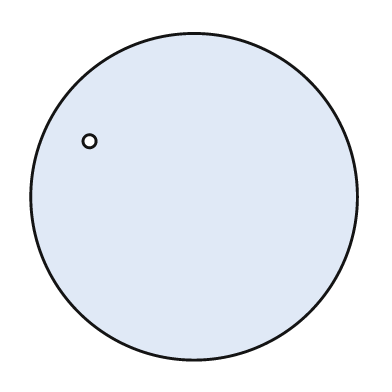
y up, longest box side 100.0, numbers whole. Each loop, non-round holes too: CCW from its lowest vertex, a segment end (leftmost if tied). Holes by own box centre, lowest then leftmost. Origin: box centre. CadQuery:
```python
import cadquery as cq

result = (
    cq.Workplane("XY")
    .moveTo(0.0, 0.0)
    .circle(50.0)
    .moveTo(-32.0, 17.0)
    .circle(2.0)
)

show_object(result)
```